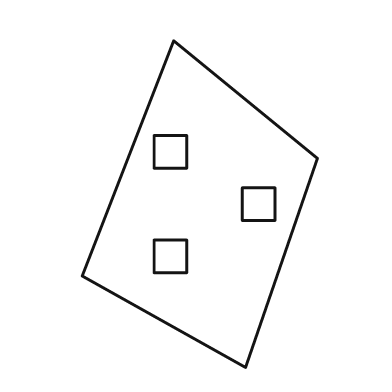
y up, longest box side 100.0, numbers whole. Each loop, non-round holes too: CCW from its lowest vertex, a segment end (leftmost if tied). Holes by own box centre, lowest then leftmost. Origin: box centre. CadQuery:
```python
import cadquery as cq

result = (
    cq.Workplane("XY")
    .moveTo(14.0, -50.0)
    .lineTo(36.0, 14.0)
    .lineTo(-8.0, 50.0)
    .lineTo(-36.0, -22.0)
    .close()
    .moveTo(-14.0, -21.0)
    .lineTo(-4.0, -21.0)
    .lineTo(-4.0, -11.0)
    .lineTo(-14.0, -11.0)
    .close()
    .moveTo(13.0, -5.0)
    .lineTo(23.0, -5.0)
    .lineTo(23.0, 5.0)
    .lineTo(13.0, 5.0)
    .close()
    .moveTo(-14.0, 11.0)
    .lineTo(-4.0, 11.0)
    .lineTo(-4.0, 21.0)
    .lineTo(-14.0, 21.0)
    .close()
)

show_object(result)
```